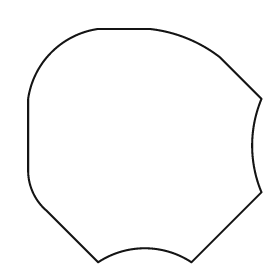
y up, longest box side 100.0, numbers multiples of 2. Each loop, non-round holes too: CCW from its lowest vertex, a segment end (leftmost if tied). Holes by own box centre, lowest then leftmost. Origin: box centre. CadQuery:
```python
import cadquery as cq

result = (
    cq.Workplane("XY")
    .moveTo(-20.0, -50.0)
    .threePointArc((0.0, -44.0), (20.0, -50.0))
    .lineTo(50.0, -20.0)
    .threePointArc((46.0, 0.0), (50.0, 20.0))
    .lineTo(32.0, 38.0)
    .threePointArc((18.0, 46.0), (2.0, 50.0))
    .lineTo(-20.0, 50.0)
    .threePointArc((-40.0, 40.0), (-50.0, 20.0))
    .lineTo(-50.0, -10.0)
    .threePointArc((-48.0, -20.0), (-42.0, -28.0))
    .close()
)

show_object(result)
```